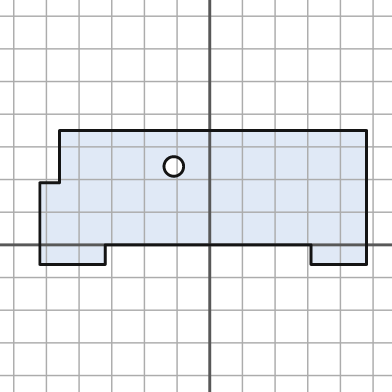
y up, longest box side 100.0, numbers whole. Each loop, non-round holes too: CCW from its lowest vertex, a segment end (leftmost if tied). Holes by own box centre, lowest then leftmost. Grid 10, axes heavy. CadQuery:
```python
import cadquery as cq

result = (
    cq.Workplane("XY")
    .moveTo(-52.0, -6.0)
    .lineTo(-32.0, -6.0)
    .lineTo(-32.0, 0.0)
    .lineTo(31.0, 0.0)
    .lineTo(31.0, -6.0)
    .lineTo(48.0, -6.0)
    .lineTo(48.0, 35.0)
    .lineTo(-46.0, 35.0)
    .lineTo(-46.0, 19.0)
    .lineTo(-52.0, 19.0)
    .close()
    .moveTo(-11.0, 24.0)
    .circle(3.0)
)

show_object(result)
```